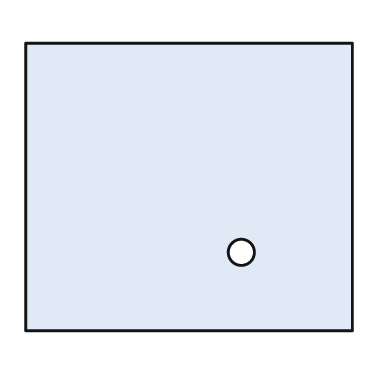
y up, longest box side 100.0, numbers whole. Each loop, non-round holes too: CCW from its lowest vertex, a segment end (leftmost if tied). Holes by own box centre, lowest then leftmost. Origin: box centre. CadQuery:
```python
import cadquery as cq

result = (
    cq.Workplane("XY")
    .moveTo(-50.0, -44.0)
    .lineTo(50.0, -44.0)
    .lineTo(50.0, 44.0)
    .lineTo(-50.0, 44.0)
    .close()
    .moveTo(16.0, -20.0)
    .circle(4.0)
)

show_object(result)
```